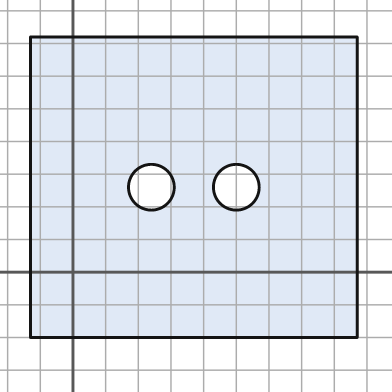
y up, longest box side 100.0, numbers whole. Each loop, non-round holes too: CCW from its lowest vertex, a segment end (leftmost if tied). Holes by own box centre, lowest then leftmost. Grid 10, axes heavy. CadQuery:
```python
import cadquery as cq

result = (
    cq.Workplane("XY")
    .moveTo(-13.0, -20.0)
    .lineTo(87.0, -20.0)
    .lineTo(87.0, 72.0)
    .lineTo(-13.0, 72.0)
    .close()
    .moveTo(24.0, 26.0)
    .circle(7.0)
    .moveTo(50.0, 26.0)
    .circle(7.0)
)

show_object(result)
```